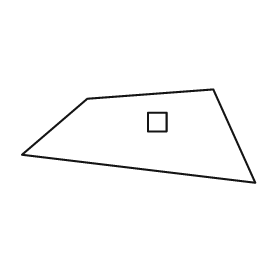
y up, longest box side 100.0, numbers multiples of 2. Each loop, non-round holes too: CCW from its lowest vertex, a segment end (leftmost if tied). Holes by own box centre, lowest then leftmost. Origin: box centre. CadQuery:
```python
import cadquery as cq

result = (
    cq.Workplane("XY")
    .moveTo(50.0, -20.0)
    .lineTo(32.0, 20.0)
    .lineTo(-22.0, 16.0)
    .lineTo(-50.0, -8.0)
    .close()
    .moveTo(4.0, 2.0)
    .lineTo(12.0, 2.0)
    .lineTo(12.0, 10.0)
    .lineTo(4.0, 10.0)
    .close()
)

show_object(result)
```